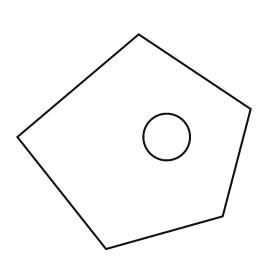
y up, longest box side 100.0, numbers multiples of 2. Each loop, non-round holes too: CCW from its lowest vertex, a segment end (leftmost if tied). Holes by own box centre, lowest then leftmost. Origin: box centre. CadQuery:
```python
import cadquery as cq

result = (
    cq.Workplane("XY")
    .moveTo(-12.0, -46.0)
    .lineTo(38.0, -32.0)
    .lineTo(50.0, 14.0)
    .lineTo(2.0, 46.0)
    .lineTo(-50.0, 2.0)
    .close()
    .moveTo(14.0, 2.0)
    .circle(10.0)
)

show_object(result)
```